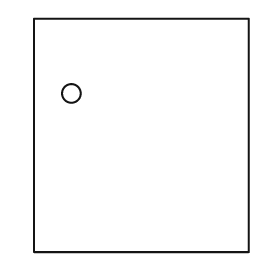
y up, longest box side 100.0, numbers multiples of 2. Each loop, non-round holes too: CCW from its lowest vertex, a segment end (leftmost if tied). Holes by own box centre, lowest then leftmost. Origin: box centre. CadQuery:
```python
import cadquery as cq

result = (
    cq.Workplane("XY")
    .moveTo(-46.0, -50.0)
    .lineTo(46.0, -50.0)
    .lineTo(46.0, 50.0)
    .lineTo(-46.0, 50.0)
    .close()
    .moveTo(-30.0, 18.0)
    .circle(4.0)
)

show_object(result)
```